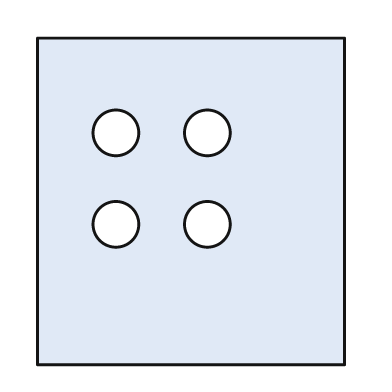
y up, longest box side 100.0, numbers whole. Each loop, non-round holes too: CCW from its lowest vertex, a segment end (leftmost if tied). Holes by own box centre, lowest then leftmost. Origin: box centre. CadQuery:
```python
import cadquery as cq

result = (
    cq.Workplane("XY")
    .moveTo(-47.0, -50.0)
    .lineTo(47.0, -50.0)
    .lineTo(47.0, 50.0)
    .lineTo(-47.0, 50.0)
    .close()
    .moveTo(-23.0, -7.0)
    .circle(7.0)
    .moveTo(5.0, -7.0)
    .circle(7.0)
    .moveTo(-23.0, 21.0)
    .circle(7.0)
    .moveTo(5.0, 21.0)
    .circle(7.0)
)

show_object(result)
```